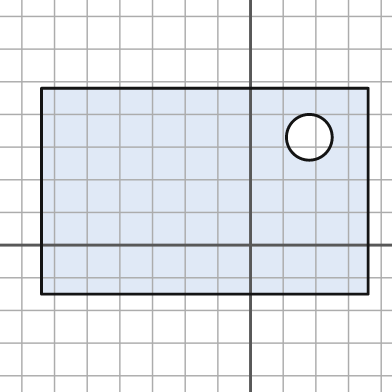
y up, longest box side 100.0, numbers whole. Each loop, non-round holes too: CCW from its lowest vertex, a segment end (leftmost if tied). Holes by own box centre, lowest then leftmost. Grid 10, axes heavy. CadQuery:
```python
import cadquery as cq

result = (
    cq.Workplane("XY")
    .moveTo(-64.0, -15.0)
    .lineTo(36.0, -15.0)
    .lineTo(36.0, 48.0)
    .lineTo(-64.0, 48.0)
    .close()
    .moveTo(18.0, 33.0)
    .circle(7.0)
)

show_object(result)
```